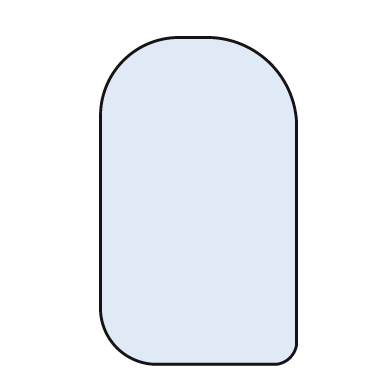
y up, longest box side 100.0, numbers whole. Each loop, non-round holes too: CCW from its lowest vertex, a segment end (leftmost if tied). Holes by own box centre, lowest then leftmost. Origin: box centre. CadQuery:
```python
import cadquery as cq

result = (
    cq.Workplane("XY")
    .moveTo(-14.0, -50.0)
    .lineTo(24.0, -50.0)
    .threePointArc((28.0, -48.0), (30.0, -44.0))
    .lineTo(30.0, 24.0)
    .threePointArc((22.0, 42.0), (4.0, 50.0))
    .lineTo(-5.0, 50.0)
    .threePointArc((-23.0, 43.0), (-30.0, 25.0))
    .lineTo(-30.0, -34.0)
    .threePointArc((-25.0, -45.0), (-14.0, -50.0))
    .close()
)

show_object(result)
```